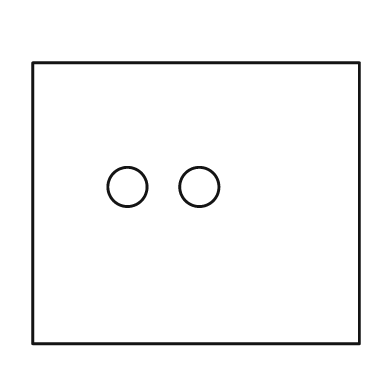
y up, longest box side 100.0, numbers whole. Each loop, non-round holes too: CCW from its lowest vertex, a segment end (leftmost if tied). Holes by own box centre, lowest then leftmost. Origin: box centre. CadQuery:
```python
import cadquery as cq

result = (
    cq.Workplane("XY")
    .moveTo(-50.0, -43.0)
    .lineTo(50.0, -43.0)
    .lineTo(50.0, 43.0)
    .lineTo(-50.0, 43.0)
    .close()
    .moveTo(-21.0, 5.0)
    .circle(6.0)
    .moveTo(1.0, 5.0)
    .circle(6.0)
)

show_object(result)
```